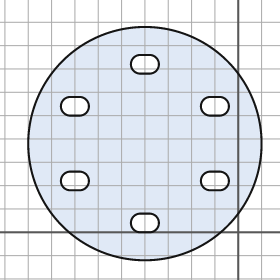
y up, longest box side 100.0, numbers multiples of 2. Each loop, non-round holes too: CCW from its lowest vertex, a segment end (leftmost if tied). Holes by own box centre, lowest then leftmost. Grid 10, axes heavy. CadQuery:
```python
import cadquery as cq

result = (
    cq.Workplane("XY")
    .moveTo(-40.0, 38.0)
    .circle(50.0)
    .moveTo(-42.0, 0.0)
    .lineTo(-38.0, 0.0)
    .threePointArc((-34.0, 4.0), (-38.0, 8.0))
    .lineTo(-42.0, 8.0)
    .threePointArc((-46.0, 4.0), (-42.0, 0.0))
    .close()
    .moveTo(-72.0, 18.0)
    .lineTo(-68.0, 18.0)
    .threePointArc((-64.0, 22.0), (-68.0, 26.0))
    .lineTo(-72.0, 26.0)
    .threePointArc((-76.0, 22.0), (-72.0, 18.0))
    .close()
    .moveTo(-12.0, 18.0)
    .lineTo(-8.0, 18.0)
    .threePointArc((-4.0, 22.0), (-8.0, 26.0))
    .lineTo(-12.0, 26.0)
    .threePointArc((-16.0, 22.0), (-12.0, 18.0))
    .close()
    .moveTo(-72.0, 50.0)
    .lineTo(-68.0, 50.0)
    .threePointArc((-64.0, 54.0), (-68.0, 58.0))
    .lineTo(-72.0, 58.0)
    .threePointArc((-76.0, 54.0), (-72.0, 50.0))
    .close()
    .moveTo(-12.0, 50.0)
    .lineTo(-8.0, 50.0)
    .threePointArc((-4.0, 54.0), (-8.0, 58.0))
    .lineTo(-12.0, 58.0)
    .threePointArc((-16.0, 54.0), (-12.0, 50.0))
    .close()
    .moveTo(-42.0, 68.0)
    .lineTo(-38.0, 68.0)
    .threePointArc((-34.0, 72.0), (-38.0, 76.0))
    .lineTo(-42.0, 76.0)
    .threePointArc((-46.0, 72.0), (-42.0, 68.0))
    .close()
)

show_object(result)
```